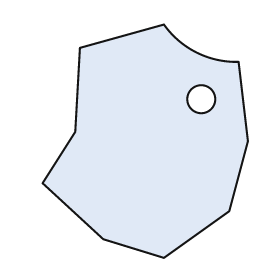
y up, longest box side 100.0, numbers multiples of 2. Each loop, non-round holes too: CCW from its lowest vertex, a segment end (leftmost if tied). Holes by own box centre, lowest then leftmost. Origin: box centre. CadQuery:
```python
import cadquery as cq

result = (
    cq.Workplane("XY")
    .moveTo(8.0, -50.0)
    .lineTo(36.0, -30.0)
    .lineTo(44.0, 0.0)
    .lineTo(40.0, 34.0)
    .threePointArc((22.0, 38.0), (8.0, 50.0))
    .lineTo(-28.0, 40.0)
    .lineTo(-30.0, 4.0)
    .lineTo(-44.0, -18.0)
    .lineTo(-18.0, -42.0)
    .close()
    .moveTo(24.0, 18.0)
    .circle(6.0)
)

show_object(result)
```